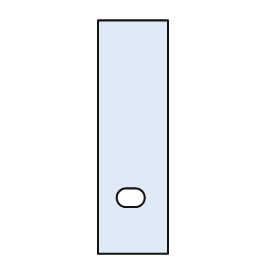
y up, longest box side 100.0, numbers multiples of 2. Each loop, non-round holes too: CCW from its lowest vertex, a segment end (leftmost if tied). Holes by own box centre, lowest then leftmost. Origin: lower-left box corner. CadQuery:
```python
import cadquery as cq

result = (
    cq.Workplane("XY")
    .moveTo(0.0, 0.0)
    .lineTo(30.0, 0.0)
    .lineTo(30.0, 100.0)
    .lineTo(0.0, 100.0)
    .close()
    .moveTo(12.0, 20.0)
    .lineTo(16.0, 20.0)
    .threePointArc((20.0, 24.0), (16.0, 28.0))
    .lineTo(12.0, 28.0)
    .threePointArc((8.0, 24.0), (12.0, 20.0))
    .close()
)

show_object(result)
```